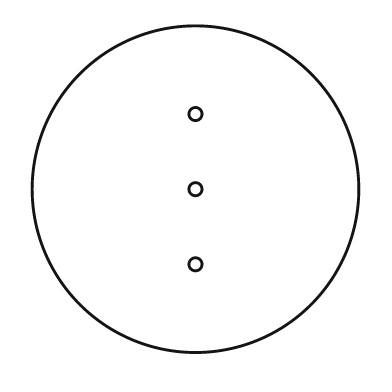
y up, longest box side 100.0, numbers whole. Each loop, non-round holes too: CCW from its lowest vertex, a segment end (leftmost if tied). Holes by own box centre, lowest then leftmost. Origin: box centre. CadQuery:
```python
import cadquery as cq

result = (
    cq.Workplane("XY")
    .moveTo(0.0, 0.0)
    .circle(50.0)
    .moveTo(0.0, -23.0)
    .circle(2.0)
    .moveTo(0.0, 0.0)
    .circle(2.0)
    .moveTo(0.0, 23.0)
    .circle(2.0)
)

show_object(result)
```